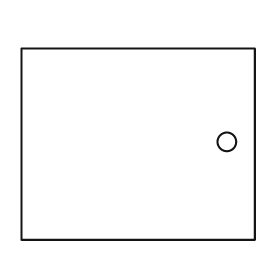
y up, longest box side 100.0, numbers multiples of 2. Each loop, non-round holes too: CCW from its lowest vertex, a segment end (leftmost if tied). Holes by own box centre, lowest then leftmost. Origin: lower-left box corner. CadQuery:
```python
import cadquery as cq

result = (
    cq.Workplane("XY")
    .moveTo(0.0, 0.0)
    .lineTo(100.0, 0.0)
    .lineTo(100.0, 82.0)
    .lineTo(0.0, 82.0)
    .close()
    .moveTo(88.0, 42.0)
    .circle(4.0)
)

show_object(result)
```